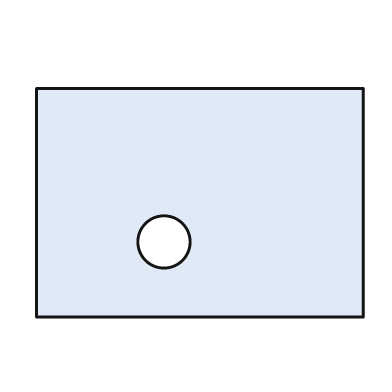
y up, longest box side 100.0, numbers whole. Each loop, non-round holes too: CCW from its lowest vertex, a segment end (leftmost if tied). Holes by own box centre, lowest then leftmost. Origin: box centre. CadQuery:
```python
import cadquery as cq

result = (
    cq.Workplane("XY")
    .moveTo(-50.0, -35.0)
    .lineTo(50.0, -35.0)
    .lineTo(50.0, 35.0)
    .lineTo(-50.0, 35.0)
    .close()
    .moveTo(-11.0, -12.0)
    .circle(8.0)
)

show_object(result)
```